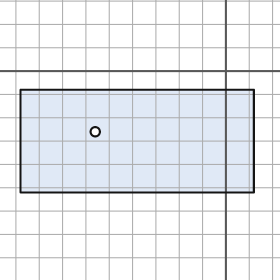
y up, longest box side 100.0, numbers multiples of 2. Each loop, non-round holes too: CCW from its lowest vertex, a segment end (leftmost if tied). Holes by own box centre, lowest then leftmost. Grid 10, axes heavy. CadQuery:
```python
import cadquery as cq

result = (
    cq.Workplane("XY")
    .moveTo(-88.0, -52.0)
    .lineTo(12.0, -52.0)
    .lineTo(12.0, -8.0)
    .lineTo(-88.0, -8.0)
    .close()
    .moveTo(-56.0, -26.0)
    .circle(2.0)
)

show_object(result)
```